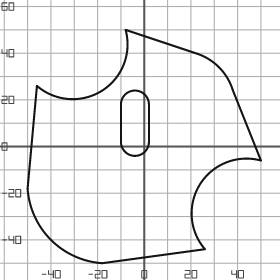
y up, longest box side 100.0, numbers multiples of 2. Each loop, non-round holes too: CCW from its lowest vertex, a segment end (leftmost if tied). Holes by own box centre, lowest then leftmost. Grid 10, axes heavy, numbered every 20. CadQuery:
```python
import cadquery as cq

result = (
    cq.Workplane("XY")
    .moveTo(-18.0, -50.0)
    .lineTo(26.0, -44.0)
    .threePointArc((24.0, -16.0), (50.0, -6.0))
    .lineTo(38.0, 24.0)
    .threePointArc((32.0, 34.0), (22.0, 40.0))
    .lineTo(-8.0, 50.0)
    .threePointArc((-18.0, 24.0), (-46.0, 26.0))
    .lineTo(-50.0, -18.0)
    .threePointArc((-40.0, -40.0), (-18.0, -50.0))
    .close()
    .moveTo(-10.0, 2.0)
    .threePointArc((-4.0, -4.0), (2.0, 2.0))
    .lineTo(2.0, 18.0)
    .threePointArc((-4.0, 24.0), (-10.0, 18.0))
    .close()
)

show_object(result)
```